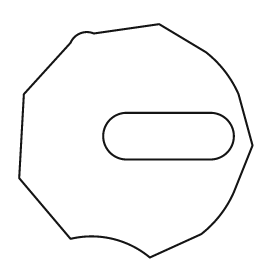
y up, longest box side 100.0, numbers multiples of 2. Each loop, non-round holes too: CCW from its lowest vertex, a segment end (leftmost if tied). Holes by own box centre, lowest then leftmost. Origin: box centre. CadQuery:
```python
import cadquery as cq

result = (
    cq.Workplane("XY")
    .moveTo(6.0, -50.0)
    .lineTo(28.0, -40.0)
    .threePointArc((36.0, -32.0), (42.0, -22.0))
    .lineTo(50.0, -2.0)
    .lineTo(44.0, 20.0)
    .threePointArc((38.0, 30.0), (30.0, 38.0))
    .lineTo(10.0, 50.0)
    .lineTo(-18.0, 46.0)
    .threePointArc((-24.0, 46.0), (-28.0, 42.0))
    .lineTo(-48.0, 20.0)
    .lineTo(-50.0, -16.0)
    .lineTo(-28.0, -42.0)
    .threePointArc((-10.0, -42.0), (6.0, -50.0))
    .close()
    .moveTo(-4.0, -8.0)
    .lineTo(32.0, -8.0)
    .threePointArc((42.0, 2.0), (32.0, 12.0))
    .lineTo(-4.0, 12.0)
    .threePointArc((-14.0, 2.0), (-4.0, -8.0))
    .close()
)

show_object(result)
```